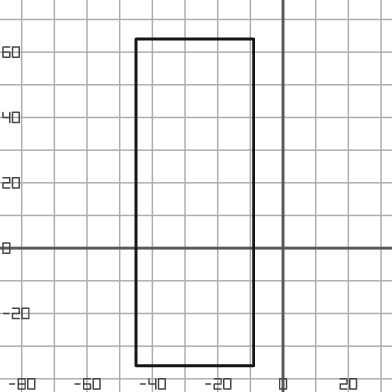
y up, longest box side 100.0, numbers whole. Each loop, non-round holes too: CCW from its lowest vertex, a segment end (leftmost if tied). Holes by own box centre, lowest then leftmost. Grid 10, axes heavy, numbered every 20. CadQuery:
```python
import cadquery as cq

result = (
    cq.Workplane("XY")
    .moveTo(-45.0, -36.0)
    .lineTo(-9.0, -36.0)
    .lineTo(-9.0, 64.0)
    .lineTo(-45.0, 64.0)
    .close()
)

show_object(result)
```